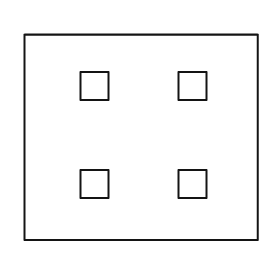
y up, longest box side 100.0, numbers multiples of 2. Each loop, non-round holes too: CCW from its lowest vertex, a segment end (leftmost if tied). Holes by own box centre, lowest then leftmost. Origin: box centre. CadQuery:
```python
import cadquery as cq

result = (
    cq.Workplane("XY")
    .moveTo(-50.0, -44.0)
    .lineTo(50.0, -44.0)
    .lineTo(50.0, 44.0)
    .lineTo(-50.0, 44.0)
    .close()
    .moveTo(-26.0, -26.0)
    .lineTo(-14.0, -26.0)
    .lineTo(-14.0, -14.0)
    .lineTo(-26.0, -14.0)
    .close()
    .moveTo(16.0, -26.0)
    .lineTo(28.0, -26.0)
    .lineTo(28.0, -14.0)
    .lineTo(16.0, -14.0)
    .close()
    .moveTo(-26.0, 16.0)
    .lineTo(-14.0, 16.0)
    .lineTo(-14.0, 28.0)
    .lineTo(-26.0, 28.0)
    .close()
    .moveTo(16.0, 16.0)
    .lineTo(28.0, 16.0)
    .lineTo(28.0, 28.0)
    .lineTo(16.0, 28.0)
    .close()
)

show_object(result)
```